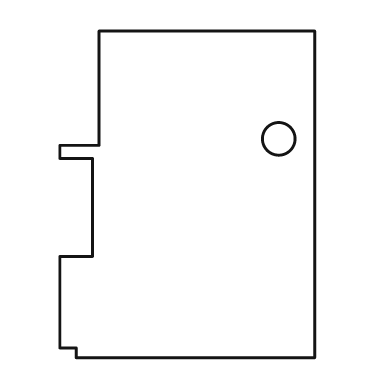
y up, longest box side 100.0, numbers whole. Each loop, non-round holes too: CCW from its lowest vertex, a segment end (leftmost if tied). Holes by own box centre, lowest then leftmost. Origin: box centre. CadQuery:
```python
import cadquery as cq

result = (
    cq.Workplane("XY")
    .moveTo(-34.0, -50.0)
    .lineTo(39.0, -50.0)
    .lineTo(39.0, 50.0)
    .lineTo(-27.0, 50.0)
    .lineTo(-27.0, 15.0)
    .lineTo(-39.0, 15.0)
    .lineTo(-39.0, 11.0)
    .lineTo(-29.0, 11.0)
    .lineTo(-29.0, -19.0)
    .lineTo(-39.0, -19.0)
    .lineTo(-39.0, -47.0)
    .lineTo(-34.0, -47.0)
    .close()
    .moveTo(28.0, 17.0)
    .circle(5.0)
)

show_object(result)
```